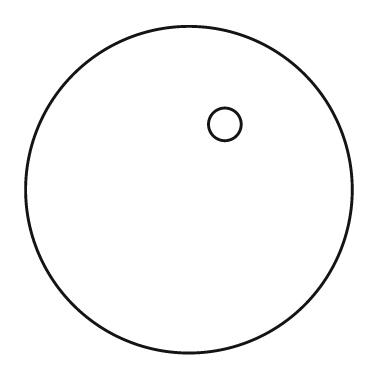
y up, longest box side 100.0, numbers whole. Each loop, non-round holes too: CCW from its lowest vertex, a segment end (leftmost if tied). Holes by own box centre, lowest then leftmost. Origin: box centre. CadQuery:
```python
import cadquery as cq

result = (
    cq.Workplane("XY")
    .moveTo(0.0, 0.0)
    .circle(50.0)
    .moveTo(11.0, 20.0)
    .circle(5.0)
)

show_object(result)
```